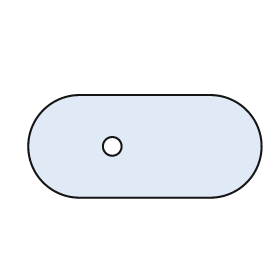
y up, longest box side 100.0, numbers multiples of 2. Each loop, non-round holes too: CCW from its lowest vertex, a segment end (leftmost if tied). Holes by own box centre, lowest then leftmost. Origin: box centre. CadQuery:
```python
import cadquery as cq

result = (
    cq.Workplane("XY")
    .moveTo(-28.0, -22.0)
    .lineTo(28.0, -22.0)
    .threePointArc((50.0, 0.0), (28.0, 22.0))
    .lineTo(-28.0, 22.0)
    .threePointArc((-50.0, 0.0), (-28.0, -22.0))
    .close()
    .moveTo(-14.0, 0.0)
    .circle(4.0)
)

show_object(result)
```